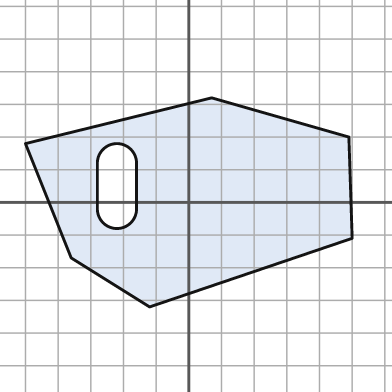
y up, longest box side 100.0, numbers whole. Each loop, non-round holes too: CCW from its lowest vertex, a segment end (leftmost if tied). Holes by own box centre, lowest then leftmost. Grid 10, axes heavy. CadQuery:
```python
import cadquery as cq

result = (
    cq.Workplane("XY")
    .moveTo(-12.0, -32.0)
    .lineTo(50.0, -11.0)
    .lineTo(49.0, 20.0)
    .lineTo(7.0, 32.0)
    .lineTo(-50.0, 18.0)
    .lineTo(-36.0, -17.0)
    .close()
    .moveTo(-28.0, -2.0)
    .threePointArc((-22.0, -8.0), (-16.0, -2.0))
    .lineTo(-16.0, 12.0)
    .threePointArc((-22.0, 18.0), (-28.0, 12.0))
    .close()
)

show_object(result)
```